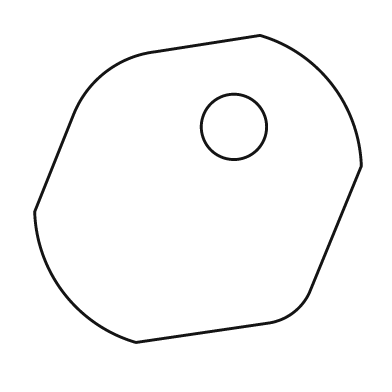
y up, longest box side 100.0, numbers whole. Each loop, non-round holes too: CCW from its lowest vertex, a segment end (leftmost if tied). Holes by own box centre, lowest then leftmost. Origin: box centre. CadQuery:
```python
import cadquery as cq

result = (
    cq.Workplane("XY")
    .moveTo(-19.0, -47.0)
    .lineTo(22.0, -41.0)
    .threePointArc((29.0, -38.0), (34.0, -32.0))
    .lineTo(50.0, 7.0)
    .threePointArc((41.0, 32.0), (19.0, 47.0))
    .lineTo(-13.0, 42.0)
    .threePointArc((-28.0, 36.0), (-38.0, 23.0))
    .lineTo(-50.0, -7.0)
    .threePointArc((-41.0, -32.0), (-19.0, -47.0))
    .close()
    .moveTo(11.0, 19.0)
    .circle(10.0)
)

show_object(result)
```